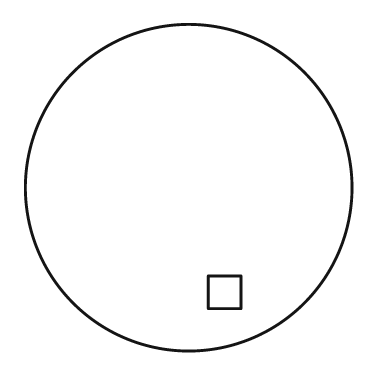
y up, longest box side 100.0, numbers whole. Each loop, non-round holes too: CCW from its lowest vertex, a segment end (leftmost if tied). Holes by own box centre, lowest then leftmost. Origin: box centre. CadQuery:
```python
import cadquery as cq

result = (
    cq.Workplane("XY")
    .moveTo(0.0, 0.0)
    .circle(50.0)
    .moveTo(6.0, -37.0)
    .lineTo(16.0, -37.0)
    .lineTo(16.0, -27.0)
    .lineTo(6.0, -27.0)
    .close()
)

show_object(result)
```